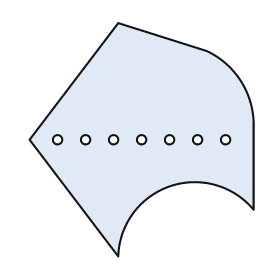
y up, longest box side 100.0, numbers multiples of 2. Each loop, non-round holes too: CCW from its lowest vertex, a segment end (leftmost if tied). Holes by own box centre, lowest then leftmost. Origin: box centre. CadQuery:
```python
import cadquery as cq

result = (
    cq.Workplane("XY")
    .moveTo(-10.0, -50.0)
    .threePointArc((12.0, -20.0), (48.0, -30.0))
    .lineTo(48.0, 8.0)
    .threePointArc((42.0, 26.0), (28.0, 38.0))
    .lineTo(-10.0, 50.0)
    .lineTo(-48.0, 0.0)
    .close()
    .moveTo(-36.0, 0.0)
    .circle(2.0)
    .moveTo(-24.0, 0.0)
    .circle(2.0)
    .moveTo(-12.0, 0.0)
    .circle(2.0)
    .moveTo(0.0, 0.0)
    .circle(2.0)
    .moveTo(12.0, 0.0)
    .circle(2.0)
    .moveTo(24.0, 0.0)
    .circle(2.0)
    .moveTo(36.0, 0.0)
    .circle(2.0)
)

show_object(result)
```